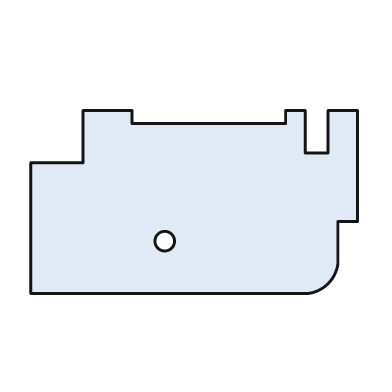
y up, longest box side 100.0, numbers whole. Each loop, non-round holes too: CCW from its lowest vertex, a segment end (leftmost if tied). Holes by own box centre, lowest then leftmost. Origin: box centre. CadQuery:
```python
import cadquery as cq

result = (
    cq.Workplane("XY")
    .moveTo(-50.0, -28.0)
    .lineTo(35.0, -28.0)
    .threePointArc((41.0, -25.0), (44.0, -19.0))
    .lineTo(44.0, -6.0)
    .lineTo(50.0, -6.0)
    .lineTo(50.0, 28.0)
    .lineTo(41.0, 28.0)
    .lineTo(41.0, 15.0)
    .lineTo(34.0, 15.0)
    .lineTo(34.0, 28.0)
    .lineTo(28.0, 28.0)
    .lineTo(28.0, 24.0)
    .lineTo(-19.0, 24.0)
    .lineTo(-19.0, 28.0)
    .lineTo(-34.0, 28.0)
    .lineTo(-34.0, 12.0)
    .lineTo(-50.0, 12.0)
    .close()
    .moveTo(-9.0, -12.0)
    .circle(3.0)
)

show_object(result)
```